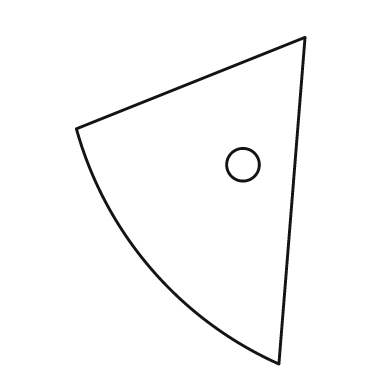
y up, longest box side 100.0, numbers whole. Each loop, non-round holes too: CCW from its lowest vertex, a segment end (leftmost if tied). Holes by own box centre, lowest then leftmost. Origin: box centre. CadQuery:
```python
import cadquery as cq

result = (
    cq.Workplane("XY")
    .moveTo(27.0, -50.0)
    .lineTo(35.0, 50.0)
    .lineTo(-35.0, 22.0)
    .threePointArc((-12.0, -21.0), (27.0, -50.0))
    .close()
    .moveTo(16.0, 11.0)
    .circle(5.0)
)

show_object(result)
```